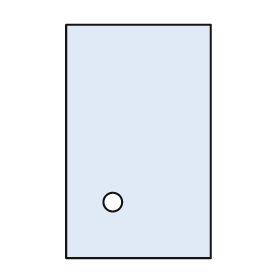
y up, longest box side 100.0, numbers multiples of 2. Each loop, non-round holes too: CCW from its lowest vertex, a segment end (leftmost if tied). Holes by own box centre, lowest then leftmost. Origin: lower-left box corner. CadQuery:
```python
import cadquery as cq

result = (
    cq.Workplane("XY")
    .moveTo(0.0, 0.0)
    .lineTo(62.0, 0.0)
    .lineTo(62.0, 100.0)
    .lineTo(0.0, 100.0)
    .close()
    .moveTo(20.0, 24.0)
    .circle(4.0)
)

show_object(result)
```